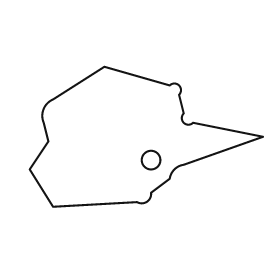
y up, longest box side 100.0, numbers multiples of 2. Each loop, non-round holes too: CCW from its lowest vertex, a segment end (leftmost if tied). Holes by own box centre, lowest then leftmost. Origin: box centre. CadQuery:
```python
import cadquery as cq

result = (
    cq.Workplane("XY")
    .moveTo(-40.0, -30.0)
    .lineTo(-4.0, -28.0)
    .threePointArc((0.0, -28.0), (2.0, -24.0))
    .lineTo(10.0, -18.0)
    .threePointArc((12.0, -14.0), (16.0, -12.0))
    .lineTo(50.0, 0.0)
    .lineTo(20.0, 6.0)
    .threePointArc((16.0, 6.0), (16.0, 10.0))
    .lineTo(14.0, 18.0)
    .threePointArc((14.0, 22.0), (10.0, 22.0))
    .lineTo(-18.0, 30.0)
    .lineTo(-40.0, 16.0)
    .threePointArc((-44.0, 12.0), (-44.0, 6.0))
    .lineTo(-42.0, -2.0)
    .lineTo(-50.0, -14.0)
    .close()
    .moveTo(2.0, -10.0)
    .circle(4.0)
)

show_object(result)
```